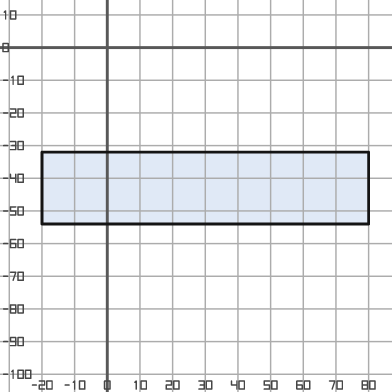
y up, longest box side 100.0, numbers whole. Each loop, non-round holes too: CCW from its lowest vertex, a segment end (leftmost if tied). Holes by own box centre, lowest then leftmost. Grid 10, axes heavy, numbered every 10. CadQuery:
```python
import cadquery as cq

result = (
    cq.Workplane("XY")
    .moveTo(-20.0, -54.0)
    .lineTo(80.0, -54.0)
    .lineTo(80.0, -32.0)
    .lineTo(-20.0, -32.0)
    .close()
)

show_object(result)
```